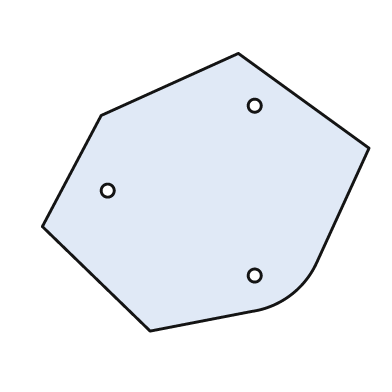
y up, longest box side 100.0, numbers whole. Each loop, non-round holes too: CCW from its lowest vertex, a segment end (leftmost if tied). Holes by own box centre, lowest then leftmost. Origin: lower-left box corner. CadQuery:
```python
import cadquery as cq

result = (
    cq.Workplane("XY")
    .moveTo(33.0, 0.0)
    .lineTo(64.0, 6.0)
    .threePointArc((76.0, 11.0), (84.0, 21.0))
    .lineTo(100.0, 56.0)
    .lineTo(60.0, 85.0)
    .lineTo(18.0, 66.0)
    .lineTo(0.0, 32.0)
    .close()
    .moveTo(65.0, 17.0)
    .circle(2.0)
    .moveTo(20.0, 43.0)
    .circle(2.0)
    .moveTo(65.0, 69.0)
    .circle(2.0)
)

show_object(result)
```